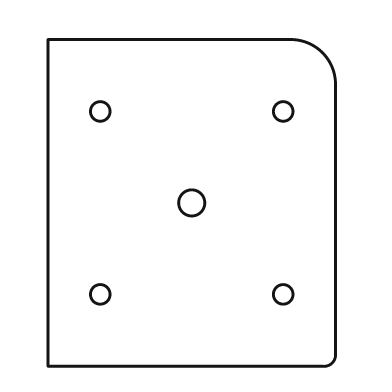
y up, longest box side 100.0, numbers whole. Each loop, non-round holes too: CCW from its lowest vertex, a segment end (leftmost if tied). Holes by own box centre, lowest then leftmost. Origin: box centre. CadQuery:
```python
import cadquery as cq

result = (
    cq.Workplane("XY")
    .moveTo(-44.0, -50.0)
    .lineTo(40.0, -50.0)
    .threePointArc((43.0, -49.0), (44.0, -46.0))
    .lineTo(44.0, 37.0)
    .threePointArc((40.0, 46.0), (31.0, 50.0))
    .lineTo(-44.0, 50.0)
    .close()
    .moveTo(-28.0, -28.0)
    .circle(3.0)
    .moveTo(28.0, -28.0)
    .circle(3.0)
    .moveTo(0.0, 0.0)
    .circle(4.0)
    .moveTo(-28.0, 28.0)
    .circle(3.0)
    .moveTo(28.0, 28.0)
    .circle(3.0)
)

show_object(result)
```